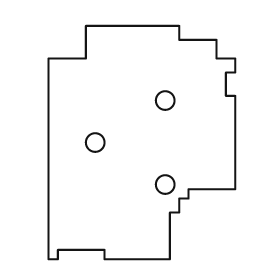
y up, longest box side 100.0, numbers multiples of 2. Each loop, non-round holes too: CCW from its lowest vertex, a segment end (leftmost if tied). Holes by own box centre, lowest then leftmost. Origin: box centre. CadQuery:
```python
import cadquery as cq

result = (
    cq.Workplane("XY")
    .moveTo(-40.0, -50.0)
    .lineTo(-36.0, -50.0)
    .lineTo(-36.0, -46.0)
    .lineTo(-16.0, -46.0)
    .lineTo(-16.0, -50.0)
    .lineTo(12.0, -50.0)
    .lineTo(12.0, -30.0)
    .lineTo(16.0, -30.0)
    .lineTo(16.0, -24.0)
    .lineTo(20.0, -24.0)
    .lineTo(20.0, -20.0)
    .lineTo(40.0, -20.0)
    .lineTo(40.0, 20.0)
    .lineTo(36.0, 20.0)
    .lineTo(36.0, 30.0)
    .lineTo(40.0, 30.0)
    .lineTo(40.0, 36.0)
    .lineTo(32.0, 36.0)
    .lineTo(32.0, 44.0)
    .lineTo(16.0, 44.0)
    .lineTo(16.0, 50.0)
    .lineTo(-24.0, 50.0)
    .lineTo(-24.0, 36.0)
    .lineTo(-40.0, 36.0)
    .close()
    .moveTo(10.0, -18.0)
    .circle(4.0)
    .moveTo(-20.0, 0.0)
    .circle(4.0)
    .moveTo(10.0, 18.0)
    .circle(4.0)
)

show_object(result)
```